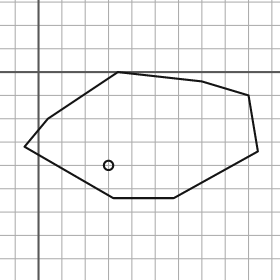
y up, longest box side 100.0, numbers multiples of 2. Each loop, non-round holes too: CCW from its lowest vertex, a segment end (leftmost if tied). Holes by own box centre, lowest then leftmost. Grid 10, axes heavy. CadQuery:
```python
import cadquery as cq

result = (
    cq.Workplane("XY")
    .moveTo(32.0, -54.0)
    .lineTo(58.0, -54.0)
    .lineTo(94.0, -34.0)
    .lineTo(90.0, -10.0)
    .lineTo(70.0, -4.0)
    .lineTo(34.0, 0.0)
    .lineTo(4.0, -20.0)
    .lineTo(-6.0, -32.0)
    .close()
    .moveTo(30.0, -40.0)
    .circle(2.0)
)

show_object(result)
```